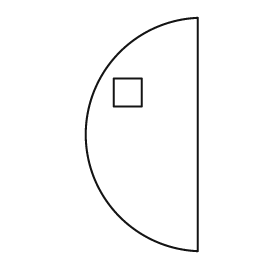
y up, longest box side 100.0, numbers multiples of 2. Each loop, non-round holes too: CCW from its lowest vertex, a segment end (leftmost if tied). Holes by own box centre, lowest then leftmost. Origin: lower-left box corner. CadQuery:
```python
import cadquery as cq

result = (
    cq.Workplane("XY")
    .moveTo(48.0, 0.0)
    .lineTo(48.0, 100.0)
    .threePointArc((0.0, 50.0), (48.0, 0.0))
    .close()
    .moveTo(12.0, 62.0)
    .lineTo(24.0, 62.0)
    .lineTo(24.0, 74.0)
    .lineTo(12.0, 74.0)
    .close()
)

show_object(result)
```